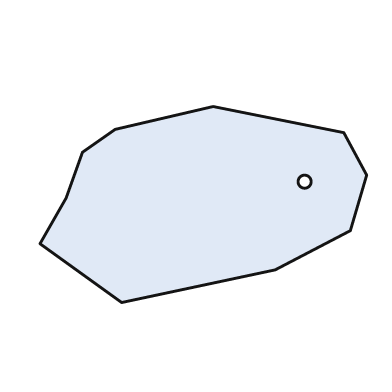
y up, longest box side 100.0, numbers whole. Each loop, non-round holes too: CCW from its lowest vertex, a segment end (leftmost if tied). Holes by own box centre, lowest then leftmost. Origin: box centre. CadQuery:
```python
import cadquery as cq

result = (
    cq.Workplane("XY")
    .moveTo(-25.0, -30.0)
    .lineTo(22.0, -20.0)
    .lineTo(45.0, -8.0)
    .lineTo(50.0, 9.0)
    .lineTo(43.0, 22.0)
    .lineTo(3.0, 30.0)
    .lineTo(-27.0, 23.0)
    .lineTo(-37.0, 16.0)
    .lineTo(-42.0, 2.0)
    .lineTo(-50.0, -12.0)
    .close()
    .moveTo(31.0, 7.0)
    .circle(2.0)
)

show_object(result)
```